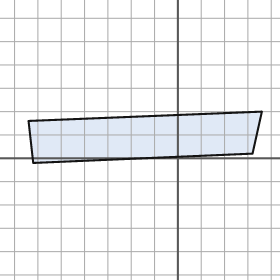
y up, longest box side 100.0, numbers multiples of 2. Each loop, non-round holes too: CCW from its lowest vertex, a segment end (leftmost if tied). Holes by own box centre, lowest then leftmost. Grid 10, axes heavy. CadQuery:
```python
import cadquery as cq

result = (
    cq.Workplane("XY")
    .moveTo(-62.0, -2.0)
    .lineTo(32.0, 2.0)
    .lineTo(36.0, 20.0)
    .lineTo(-64.0, 16.0)
    .close()
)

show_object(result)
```